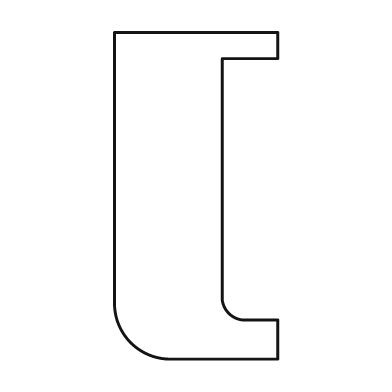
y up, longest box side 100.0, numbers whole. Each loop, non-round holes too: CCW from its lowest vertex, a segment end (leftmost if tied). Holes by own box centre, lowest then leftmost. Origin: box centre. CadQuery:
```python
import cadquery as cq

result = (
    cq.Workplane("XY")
    .moveTo(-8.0, -50.0)
    .lineTo(25.0, -50.0)
    .lineTo(25.0, -38.0)
    .lineTo(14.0, -38.0)
    .threePointArc((10.0, -36.0), (8.0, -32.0))
    .lineTo(8.0, 42.0)
    .lineTo(25.0, 42.0)
    .lineTo(25.0, 50.0)
    .lineTo(-25.0, 50.0)
    .lineTo(-25.0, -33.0)
    .threePointArc((-20.0, -45.0), (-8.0, -50.0))
    .close()
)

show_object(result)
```